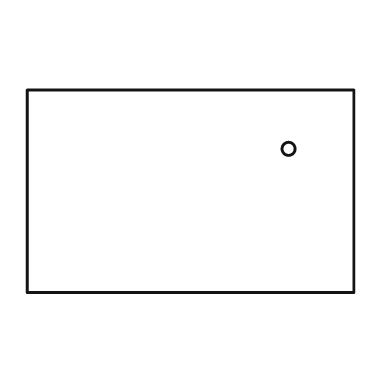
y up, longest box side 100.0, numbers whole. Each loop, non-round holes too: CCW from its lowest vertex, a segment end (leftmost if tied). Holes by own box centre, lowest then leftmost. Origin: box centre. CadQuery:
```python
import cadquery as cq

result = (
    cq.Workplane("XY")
    .moveTo(-50.0, -31.0)
    .lineTo(50.0, -31.0)
    .lineTo(50.0, 31.0)
    .lineTo(-50.0, 31.0)
    .close()
    .moveTo(30.0, 13.0)
    .circle(2.0)
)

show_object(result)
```